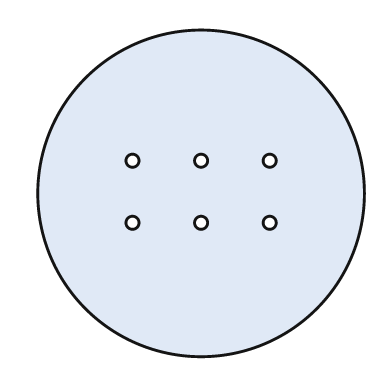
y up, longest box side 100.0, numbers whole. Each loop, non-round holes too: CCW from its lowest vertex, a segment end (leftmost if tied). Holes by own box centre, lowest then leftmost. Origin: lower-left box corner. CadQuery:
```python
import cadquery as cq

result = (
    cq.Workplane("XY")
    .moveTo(50.0, 50.0)
    .circle(50.0)
    .moveTo(29.0, 41.0)
    .circle(2.0)
    .moveTo(50.0, 41.0)
    .circle(2.0)
    .moveTo(71.0, 41.0)
    .circle(2.0)
    .moveTo(29.0, 60.0)
    .circle(2.0)
    .moveTo(50.0, 60.0)
    .circle(2.0)
    .moveTo(71.0, 60.0)
    .circle(2.0)
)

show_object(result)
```